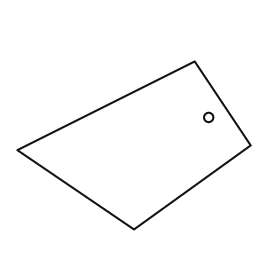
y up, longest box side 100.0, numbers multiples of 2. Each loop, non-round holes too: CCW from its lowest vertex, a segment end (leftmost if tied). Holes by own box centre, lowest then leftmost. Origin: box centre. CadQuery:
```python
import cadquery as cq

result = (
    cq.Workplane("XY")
    .moveTo(0.0, -36.0)
    .lineTo(50.0, 0.0)
    .lineTo(26.0, 36.0)
    .lineTo(-50.0, -2.0)
    .close()
    .moveTo(32.0, 12.0)
    .circle(2.0)
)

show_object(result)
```